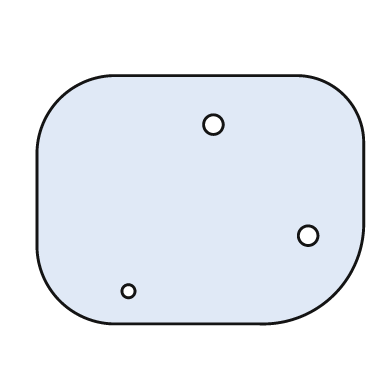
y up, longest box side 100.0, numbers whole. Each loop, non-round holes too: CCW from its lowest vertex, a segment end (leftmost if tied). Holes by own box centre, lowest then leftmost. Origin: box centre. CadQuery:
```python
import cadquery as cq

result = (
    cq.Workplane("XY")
    .moveTo(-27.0, -38.0)
    .lineTo(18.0, -38.0)
    .threePointArc((41.0, -29.0), (50.0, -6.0))
    .lineTo(50.0, 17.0)
    .threePointArc((44.0, 32.0), (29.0, 38.0))
    .lineTo(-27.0, 38.0)
    .threePointArc((-43.0, 31.0), (-50.0, 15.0))
    .lineTo(-50.0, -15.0)
    .threePointArc((-43.0, -31.0), (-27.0, -38.0))
    .close()
    .moveTo(-22.0, -28.0)
    .circle(2.0)
    .moveTo(33.0, -11.0)
    .circle(3.0)
    .moveTo(4.0, 23.0)
    .circle(3.0)
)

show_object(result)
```